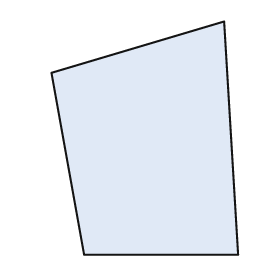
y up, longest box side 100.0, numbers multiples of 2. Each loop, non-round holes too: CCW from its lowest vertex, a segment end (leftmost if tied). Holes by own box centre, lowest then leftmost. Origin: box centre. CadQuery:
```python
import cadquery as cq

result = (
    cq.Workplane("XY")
    .moveTo(-26.0, -50.0)
    .lineTo(40.0, -50.0)
    .lineTo(34.0, 50.0)
    .lineTo(-40.0, 28.0)
    .close()
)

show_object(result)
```